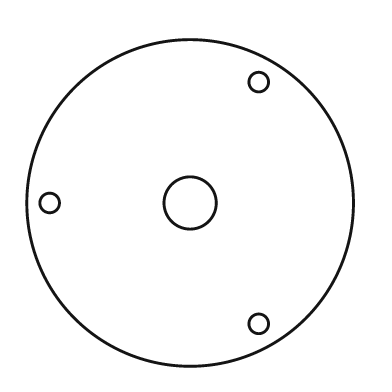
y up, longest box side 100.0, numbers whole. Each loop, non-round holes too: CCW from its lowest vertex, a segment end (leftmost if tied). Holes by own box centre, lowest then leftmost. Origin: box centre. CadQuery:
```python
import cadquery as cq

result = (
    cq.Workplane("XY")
    .moveTo(0.0, 0.0)
    .circle(50.0)
    .moveTo(21.0, -37.0)
    .circle(3.0)
    .moveTo(-43.0, 0.0)
    .circle(3.0)
    .moveTo(0.0, 0.0)
    .circle(8.0)
    .moveTo(21.0, 37.0)
    .circle(3.0)
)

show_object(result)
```